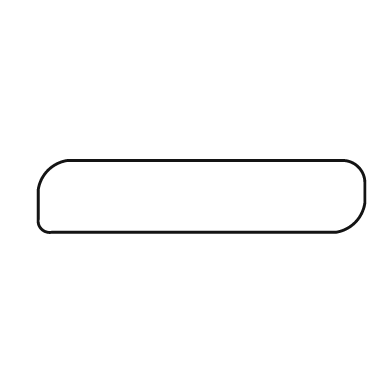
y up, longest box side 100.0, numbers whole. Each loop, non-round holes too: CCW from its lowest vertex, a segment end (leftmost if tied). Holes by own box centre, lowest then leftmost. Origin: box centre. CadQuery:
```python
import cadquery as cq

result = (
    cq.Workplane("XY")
    .moveTo(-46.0, -11.0)
    .lineTo(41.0, -11.0)
    .threePointArc((47.0, -8.0), (50.0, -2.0))
    .lineTo(50.0, 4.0)
    .threePointArc((48.0, 9.0), (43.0, 11.0))
    .lineTo(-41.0, 11.0)
    .threePointArc((-47.0, 8.0), (-50.0, 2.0))
    .lineTo(-50.0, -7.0)
    .threePointArc((-49.0, -10.0), (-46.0, -11.0))
    .close()
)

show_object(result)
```